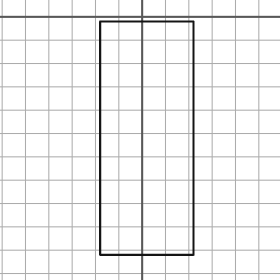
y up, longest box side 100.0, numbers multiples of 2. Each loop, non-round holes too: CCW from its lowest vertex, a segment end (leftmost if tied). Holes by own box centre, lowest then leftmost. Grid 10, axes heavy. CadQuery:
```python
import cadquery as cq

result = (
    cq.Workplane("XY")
    .moveTo(-18.0, -102.0)
    .lineTo(22.0, -102.0)
    .lineTo(22.0, -2.0)
    .lineTo(-18.0, -2.0)
    .close()
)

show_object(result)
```